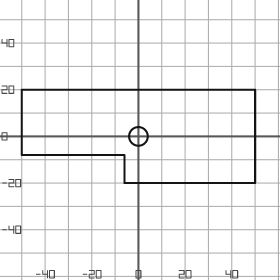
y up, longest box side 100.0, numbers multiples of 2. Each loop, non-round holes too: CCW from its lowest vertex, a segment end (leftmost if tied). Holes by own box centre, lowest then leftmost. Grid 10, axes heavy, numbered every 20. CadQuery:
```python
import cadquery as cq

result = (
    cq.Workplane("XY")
    .moveTo(-6.0, -20.0)
    .lineTo(50.0, -20.0)
    .lineTo(50.0, 20.0)
    .lineTo(-50.0, 20.0)
    .lineTo(-50.0, -8.0)
    .lineTo(-6.0, -8.0)
    .close()
    .moveTo(0.0, 0.0)
    .circle(4.0)
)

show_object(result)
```